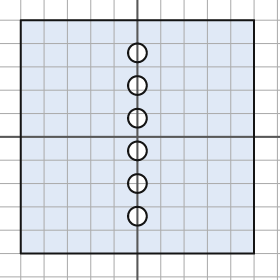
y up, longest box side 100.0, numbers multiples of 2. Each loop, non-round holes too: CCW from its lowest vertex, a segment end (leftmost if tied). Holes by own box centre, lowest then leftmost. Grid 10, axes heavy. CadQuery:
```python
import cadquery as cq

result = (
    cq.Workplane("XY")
    .moveTo(-50.0, -50.0)
    .lineTo(50.0, -50.0)
    .lineTo(50.0, 50.0)
    .lineTo(-50.0, 50.0)
    .close()
    .moveTo(0.0, -34.0)
    .circle(4.0)
    .moveTo(0.0, -20.0)
    .circle(4.0)
    .moveTo(0.0, -6.0)
    .circle(4.0)
    .moveTo(0.0, 8.0)
    .circle(4.0)
    .moveTo(0.0, 22.0)
    .circle(4.0)
    .moveTo(0.0, 36.0)
    .circle(4.0)
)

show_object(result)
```